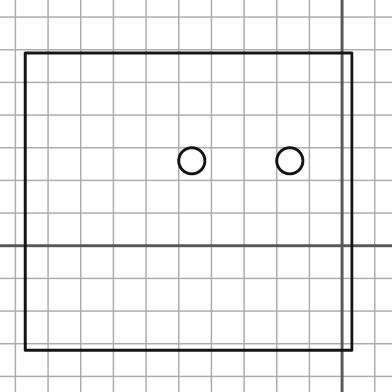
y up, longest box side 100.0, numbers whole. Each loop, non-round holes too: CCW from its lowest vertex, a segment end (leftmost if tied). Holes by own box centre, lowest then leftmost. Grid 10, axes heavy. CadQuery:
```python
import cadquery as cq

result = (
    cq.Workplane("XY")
    .moveTo(-97.0, -32.0)
    .lineTo(3.0, -32.0)
    .lineTo(3.0, 59.0)
    .lineTo(-97.0, 59.0)
    .close()
    .moveTo(-46.0, 26.0)
    .circle(4.0)
    .moveTo(-16.0, 26.0)
    .circle(4.0)
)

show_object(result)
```